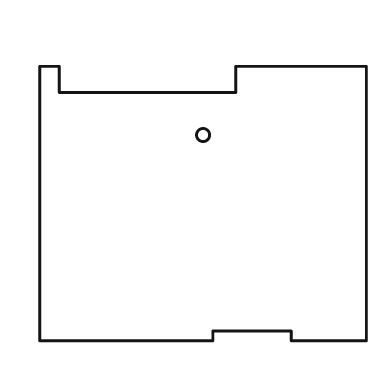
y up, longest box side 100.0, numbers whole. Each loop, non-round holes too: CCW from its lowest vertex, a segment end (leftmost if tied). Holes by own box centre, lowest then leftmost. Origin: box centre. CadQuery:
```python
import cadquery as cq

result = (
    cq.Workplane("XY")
    .moveTo(-50.0, -42.0)
    .lineTo(3.0, -42.0)
    .lineTo(3.0, -39.0)
    .lineTo(27.0, -39.0)
    .lineTo(27.0, -42.0)
    .lineTo(50.0, -42.0)
    .lineTo(50.0, 42.0)
    .lineTo(10.0, 42.0)
    .lineTo(10.0, 34.0)
    .lineTo(-44.0, 34.0)
    .lineTo(-44.0, 42.0)
    .lineTo(-50.0, 42.0)
    .close()
    .moveTo(0.0, 21.0)
    .circle(2.0)
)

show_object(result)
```